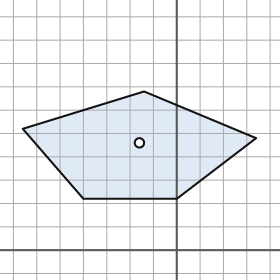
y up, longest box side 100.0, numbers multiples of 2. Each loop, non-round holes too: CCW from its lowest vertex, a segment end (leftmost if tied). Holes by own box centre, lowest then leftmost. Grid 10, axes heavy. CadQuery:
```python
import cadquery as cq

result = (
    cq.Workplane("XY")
    .moveTo(-40.0, 22.0)
    .lineTo(0.0, 22.0)
    .lineTo(34.0, 48.0)
    .lineTo(-14.0, 68.0)
    .lineTo(-66.0, 52.0)
    .close()
    .moveTo(-16.0, 46.0)
    .circle(2.0)
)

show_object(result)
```